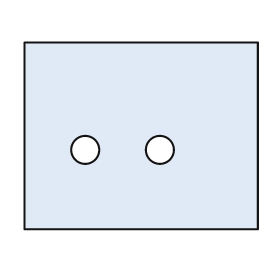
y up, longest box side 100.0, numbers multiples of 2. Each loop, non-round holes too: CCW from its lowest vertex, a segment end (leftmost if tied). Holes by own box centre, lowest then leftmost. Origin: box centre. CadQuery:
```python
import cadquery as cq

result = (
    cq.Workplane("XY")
    .moveTo(-50.0, -40.0)
    .lineTo(50.0, -40.0)
    .lineTo(50.0, 40.0)
    .lineTo(-50.0, 40.0)
    .close()
    .moveTo(-24.0, -6.0)
    .circle(6.0)
    .moveTo(8.0, -6.0)
    .circle(6.0)
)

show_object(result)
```